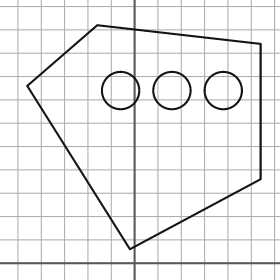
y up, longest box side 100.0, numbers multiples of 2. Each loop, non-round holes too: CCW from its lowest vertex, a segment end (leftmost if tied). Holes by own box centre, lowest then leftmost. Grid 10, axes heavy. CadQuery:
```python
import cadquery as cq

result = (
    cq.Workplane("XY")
    .moveTo(-2.0, 6.0)
    .lineTo(54.0, 36.0)
    .lineTo(54.0, 94.0)
    .lineTo(-16.0, 102.0)
    .lineTo(-46.0, 76.0)
    .close()
    .moveTo(-6.0, 74.0)
    .circle(8.0)
    .moveTo(16.0, 74.0)
    .circle(8.0)
    .moveTo(38.0, 74.0)
    .circle(8.0)
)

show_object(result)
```